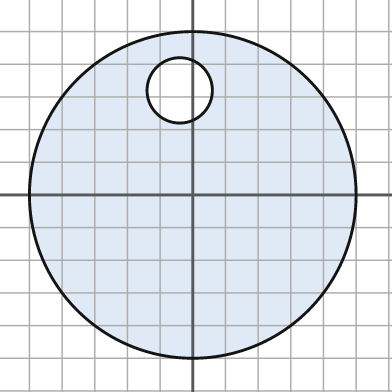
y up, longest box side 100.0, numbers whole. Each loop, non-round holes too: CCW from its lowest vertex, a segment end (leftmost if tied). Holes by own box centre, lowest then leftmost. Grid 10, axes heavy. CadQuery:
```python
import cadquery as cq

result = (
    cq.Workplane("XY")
    .moveTo(0.0, 0.0)
    .circle(50.0)
    .moveTo(-4.0, 32.0)
    .circle(10.0)
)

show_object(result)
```